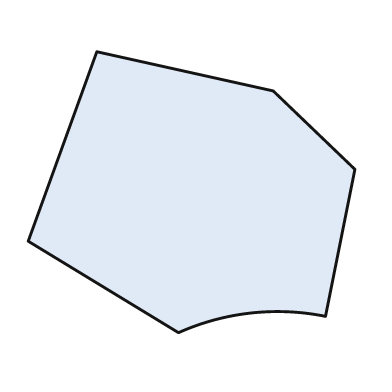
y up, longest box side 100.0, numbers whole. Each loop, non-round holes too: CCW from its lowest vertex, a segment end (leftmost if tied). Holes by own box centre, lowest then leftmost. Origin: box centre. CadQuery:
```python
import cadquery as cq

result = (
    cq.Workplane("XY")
    .moveTo(-4.0, -43.0)
    .threePointArc((18.0, -37.0), (41.0, -38.0))
    .lineTo(50.0, 7.0)
    .lineTo(25.0, 31.0)
    .lineTo(-29.0, 43.0)
    .lineTo(-50.0, -15.0)
    .close()
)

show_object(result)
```